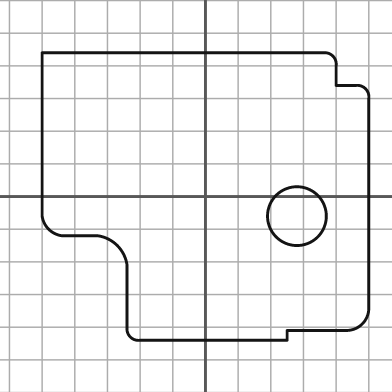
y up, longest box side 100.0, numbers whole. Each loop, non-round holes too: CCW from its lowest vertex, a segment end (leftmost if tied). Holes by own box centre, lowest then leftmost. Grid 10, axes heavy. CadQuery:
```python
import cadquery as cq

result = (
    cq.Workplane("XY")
    .moveTo(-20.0, -44.0)
    .lineTo(25.0, -44.0)
    .lineTo(25.0, -41.0)
    .lineTo(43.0, -41.0)
    .threePointArc((48.0, -39.0), (50.0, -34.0))
    .lineTo(50.0, 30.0)
    .threePointArc((49.0, 33.0), (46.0, 34.0))
    .lineTo(40.0, 34.0)
    .lineTo(40.0, 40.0)
    .threePointArc((39.0, 43.0), (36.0, 44.0))
    .lineTo(-50.0, 44.0)
    .lineTo(-50.0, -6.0)
    .threePointArc((-48.0, -10.0), (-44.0, -12.0))
    .lineTo(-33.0, -12.0)
    .threePointArc((-27.0, -15.0), (-24.0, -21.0))
    .lineTo(-24.0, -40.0)
    .threePointArc((-23.0, -43.0), (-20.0, -44.0))
    .close()
    .moveTo(28.0, -6.0)
    .circle(9.0)
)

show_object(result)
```